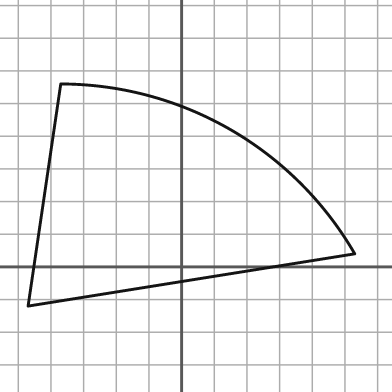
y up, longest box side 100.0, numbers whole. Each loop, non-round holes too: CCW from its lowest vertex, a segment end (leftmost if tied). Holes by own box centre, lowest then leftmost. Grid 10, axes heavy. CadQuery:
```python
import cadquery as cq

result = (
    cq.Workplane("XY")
    .moveTo(-47.0, -12.0)
    .lineTo(53.0, 4.0)
    .threePointArc((15.0, 42.0), (-37.0, 56.0))
    .close()
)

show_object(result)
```